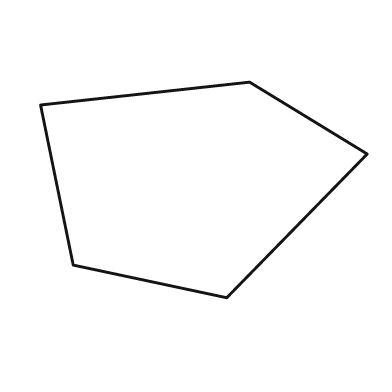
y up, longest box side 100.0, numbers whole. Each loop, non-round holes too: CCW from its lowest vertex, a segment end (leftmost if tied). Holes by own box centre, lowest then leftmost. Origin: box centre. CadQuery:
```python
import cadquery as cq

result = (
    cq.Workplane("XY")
    .moveTo(7.0, -33.0)
    .lineTo(50.0, 11.0)
    .lineTo(14.0, 33.0)
    .lineTo(-50.0, 26.0)
    .lineTo(-40.0, -23.0)
    .close()
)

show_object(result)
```